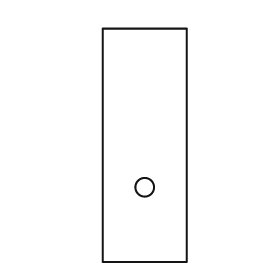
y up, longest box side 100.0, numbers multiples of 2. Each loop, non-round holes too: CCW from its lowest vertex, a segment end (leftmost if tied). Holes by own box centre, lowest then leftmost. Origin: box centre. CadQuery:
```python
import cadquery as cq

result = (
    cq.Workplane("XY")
    .moveTo(-18.0, -50.0)
    .lineTo(18.0, -50.0)
    .lineTo(18.0, 50.0)
    .lineTo(-18.0, 50.0)
    .close()
    .moveTo(0.0, -18.0)
    .circle(4.0)
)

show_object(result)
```